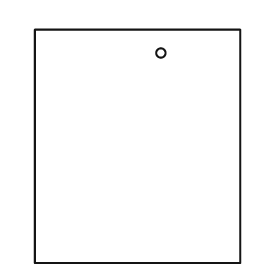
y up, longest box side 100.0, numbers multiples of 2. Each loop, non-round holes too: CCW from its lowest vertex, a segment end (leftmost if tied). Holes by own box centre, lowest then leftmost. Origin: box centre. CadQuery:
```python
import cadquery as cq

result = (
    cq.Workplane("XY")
    .moveTo(-44.0, -50.0)
    .lineTo(44.0, -50.0)
    .lineTo(44.0, 50.0)
    .lineTo(-44.0, 50.0)
    .close()
    .moveTo(10.0, 40.0)
    .circle(2.0)
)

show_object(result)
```